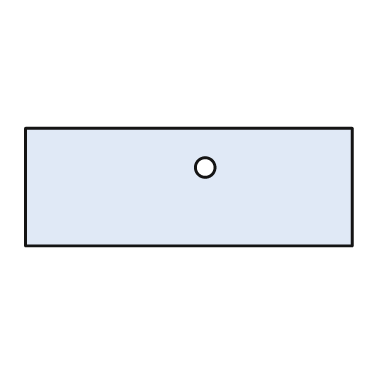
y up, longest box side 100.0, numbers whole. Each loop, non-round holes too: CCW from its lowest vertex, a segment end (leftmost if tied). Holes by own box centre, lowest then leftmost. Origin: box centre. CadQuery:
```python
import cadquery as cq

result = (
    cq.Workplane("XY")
    .moveTo(-50.0, -18.0)
    .lineTo(50.0, -18.0)
    .lineTo(50.0, 18.0)
    .lineTo(-50.0, 18.0)
    .close()
    .moveTo(5.0, 6.0)
    .circle(3.0)
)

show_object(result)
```